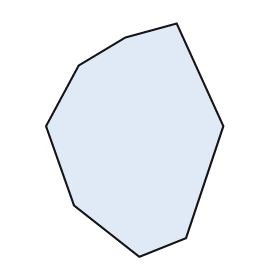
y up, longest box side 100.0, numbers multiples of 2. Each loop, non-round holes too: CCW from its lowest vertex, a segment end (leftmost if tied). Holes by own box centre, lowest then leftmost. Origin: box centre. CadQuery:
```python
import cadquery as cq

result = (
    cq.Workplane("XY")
    .moveTo(2.0, -50.0)
    .lineTo(22.0, -42.0)
    .lineTo(38.0, 6.0)
    .lineTo(18.0, 50.0)
    .lineTo(-4.0, 44.0)
    .lineTo(-24.0, 32.0)
    .lineTo(-38.0, 6.0)
    .lineTo(-26.0, -28.0)
    .close()
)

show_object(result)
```